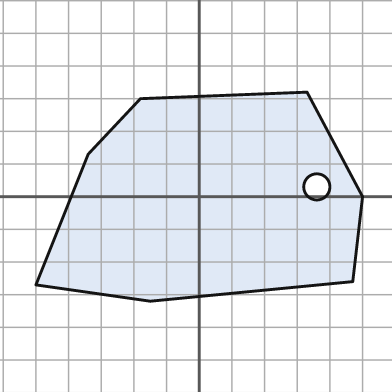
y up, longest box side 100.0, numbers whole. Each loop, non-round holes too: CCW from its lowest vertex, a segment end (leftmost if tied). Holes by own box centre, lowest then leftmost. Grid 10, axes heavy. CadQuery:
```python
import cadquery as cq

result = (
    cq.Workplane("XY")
    .moveTo(-15.0, -32.0)
    .lineTo(47.0, -26.0)
    .lineTo(50.0, 0.0)
    .lineTo(33.0, 32.0)
    .lineTo(-18.0, 30.0)
    .lineTo(-34.0, 13.0)
    .lineTo(-50.0, -27.0)
    .close()
    .moveTo(36.0, 3.0)
    .circle(4.0)
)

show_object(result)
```